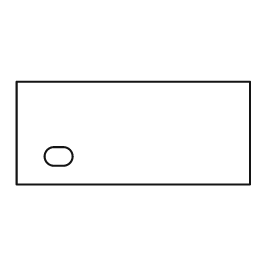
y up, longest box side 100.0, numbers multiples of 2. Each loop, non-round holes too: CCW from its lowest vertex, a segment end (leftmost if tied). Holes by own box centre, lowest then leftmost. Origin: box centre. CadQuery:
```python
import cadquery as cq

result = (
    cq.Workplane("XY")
    .moveTo(-50.0, -22.0)
    .lineTo(50.0, -22.0)
    .lineTo(50.0, 22.0)
    .lineTo(-50.0, 22.0)
    .close()
    .moveTo(-34.0, -14.0)
    .lineTo(-30.0, -14.0)
    .threePointArc((-26.0, -10.0), (-30.0, -6.0))
    .lineTo(-34.0, -6.0)
    .threePointArc((-38.0, -10.0), (-34.0, -14.0))
    .close()
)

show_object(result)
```